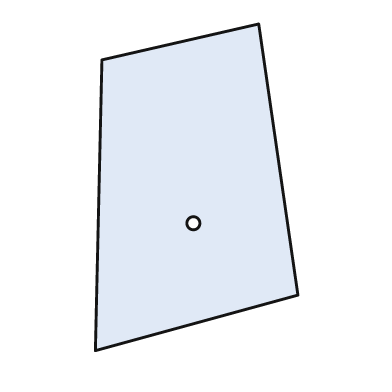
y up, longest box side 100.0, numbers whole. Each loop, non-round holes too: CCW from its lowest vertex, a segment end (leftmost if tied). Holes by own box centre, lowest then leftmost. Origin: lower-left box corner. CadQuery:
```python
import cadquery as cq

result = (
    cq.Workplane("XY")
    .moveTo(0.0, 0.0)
    .lineTo(62.0, 17.0)
    .lineTo(50.0, 100.0)
    .lineTo(2.0, 89.0)
    .close()
    .moveTo(30.0, 39.0)
    .circle(2.0)
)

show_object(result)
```